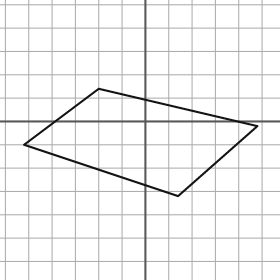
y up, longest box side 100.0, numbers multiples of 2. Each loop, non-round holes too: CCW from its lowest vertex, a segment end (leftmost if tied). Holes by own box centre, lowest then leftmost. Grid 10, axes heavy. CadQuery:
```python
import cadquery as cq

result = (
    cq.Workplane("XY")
    .moveTo(14.0, -32.0)
    .lineTo(48.0, -2.0)
    .lineTo(-20.0, 14.0)
    .lineTo(-52.0, -10.0)
    .close()
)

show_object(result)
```